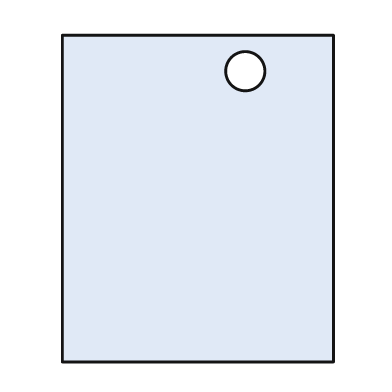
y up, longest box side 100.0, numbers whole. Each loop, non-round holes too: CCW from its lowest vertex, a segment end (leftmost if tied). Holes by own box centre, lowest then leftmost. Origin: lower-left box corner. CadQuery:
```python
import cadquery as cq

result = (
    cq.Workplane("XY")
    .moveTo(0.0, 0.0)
    .lineTo(83.0, 0.0)
    .lineTo(83.0, 100.0)
    .lineTo(0.0, 100.0)
    .close()
    .moveTo(56.0, 89.0)
    .circle(6.0)
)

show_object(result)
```